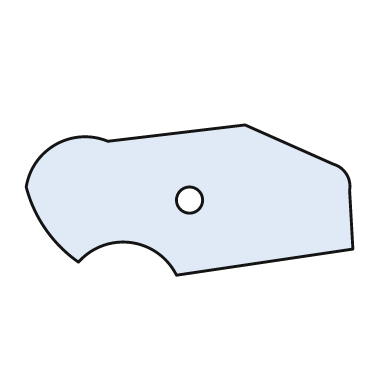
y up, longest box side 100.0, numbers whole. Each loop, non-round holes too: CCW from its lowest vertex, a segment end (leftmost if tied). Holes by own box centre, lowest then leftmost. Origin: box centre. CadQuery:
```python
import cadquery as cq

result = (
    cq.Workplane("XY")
    .moveTo(-4.0, -23.0)
    .lineTo(50.0, -15.0)
    .lineTo(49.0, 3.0)
    .threePointArc((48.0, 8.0), (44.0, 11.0))
    .lineTo(17.0, 23.0)
    .lineTo(-25.0, 18.0)
    .threePointArc((-41.0, 17.0), (-50.0, 4.0))
    .threePointArc((-44.0, -9.0), (-34.0, -19.0))
    .threePointArc((-18.0, -13.0), (-4.0, -23.0))
    .close()
    .moveTo(0.0, 0.0)
    .circle(4.0)
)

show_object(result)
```